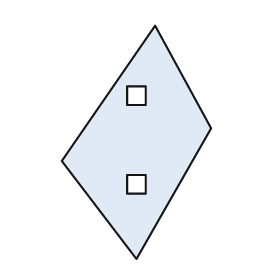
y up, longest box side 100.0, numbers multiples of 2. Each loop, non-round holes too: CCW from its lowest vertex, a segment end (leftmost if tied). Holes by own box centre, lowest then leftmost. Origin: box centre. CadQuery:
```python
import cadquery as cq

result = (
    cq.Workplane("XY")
    .moveTo(0.0, -50.0)
    .lineTo(32.0, 6.0)
    .lineTo(8.0, 50.0)
    .lineTo(-32.0, -8.0)
    .close()
    .moveTo(-4.0, -22.0)
    .lineTo(4.0, -22.0)
    .lineTo(4.0, -14.0)
    .lineTo(-4.0, -14.0)
    .close()
    .moveTo(-4.0, 16.0)
    .lineTo(4.0, 16.0)
    .lineTo(4.0, 24.0)
    .lineTo(-4.0, 24.0)
    .close()
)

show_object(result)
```